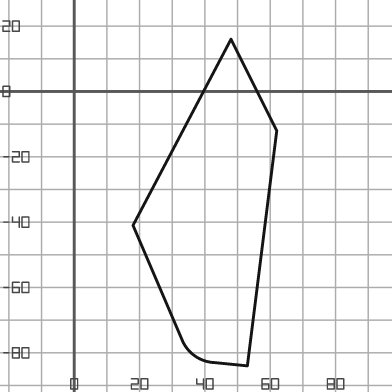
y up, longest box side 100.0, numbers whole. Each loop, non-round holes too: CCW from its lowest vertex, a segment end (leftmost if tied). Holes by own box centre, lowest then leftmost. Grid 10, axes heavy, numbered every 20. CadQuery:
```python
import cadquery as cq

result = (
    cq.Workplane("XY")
    .moveTo(53.0, -84.0)
    .lineTo(62.0, -12.0)
    .lineTo(48.0, 16.0)
    .lineTo(18.0, -41.0)
    .lineTo(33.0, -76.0)
    .threePointArc((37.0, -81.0), (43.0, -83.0))
    .close()
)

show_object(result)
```